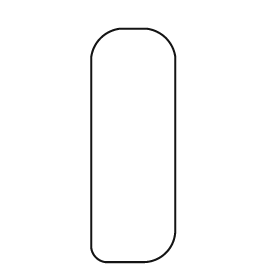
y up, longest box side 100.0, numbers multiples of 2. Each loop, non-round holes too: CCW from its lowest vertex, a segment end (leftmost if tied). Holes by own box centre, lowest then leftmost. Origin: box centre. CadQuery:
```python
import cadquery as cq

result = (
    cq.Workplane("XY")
    .moveTo(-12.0, -50.0)
    .lineTo(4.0, -50.0)
    .threePointArc((14.0, -46.0), (18.0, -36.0))
    .lineTo(18.0, 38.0)
    .threePointArc((14.0, 46.0), (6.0, 50.0))
    .lineTo(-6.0, 50.0)
    .threePointArc((-14.0, 46.0), (-18.0, 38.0))
    .lineTo(-18.0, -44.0)
    .threePointArc((-16.0, -48.0), (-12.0, -50.0))
    .close()
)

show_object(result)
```